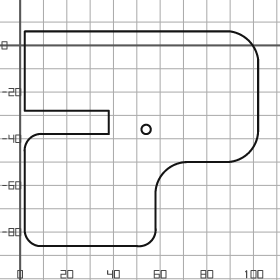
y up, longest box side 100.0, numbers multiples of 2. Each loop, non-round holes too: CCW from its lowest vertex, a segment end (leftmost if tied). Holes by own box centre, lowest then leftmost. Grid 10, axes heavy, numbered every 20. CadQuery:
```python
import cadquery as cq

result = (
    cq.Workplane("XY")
    .moveTo(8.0, -86.0)
    .lineTo(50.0, -86.0)
    .threePointArc((56.0, -84.0), (58.0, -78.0))
    .lineTo(58.0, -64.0)
    .threePointArc((62.0, -54.0), (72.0, -50.0))
    .lineTo(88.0, -50.0)
    .threePointArc((98.0, -46.0), (102.0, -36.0))
    .lineTo(102.0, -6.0)
    .threePointArc((98.0, 2.0), (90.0, 6.0))
    .lineTo(2.0, 6.0)
    .lineTo(2.0, -28.0)
    .lineTo(38.0, -28.0)
    .lineTo(38.0, -38.0)
    .lineTo(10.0, -38.0)
    .threePointArc((4.0, -40.0), (2.0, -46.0))
    .lineTo(2.0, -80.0)
    .threePointArc((4.0, -84.0), (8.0, -86.0))
    .close()
    .moveTo(54.0, -36.0)
    .circle(2.0)
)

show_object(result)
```